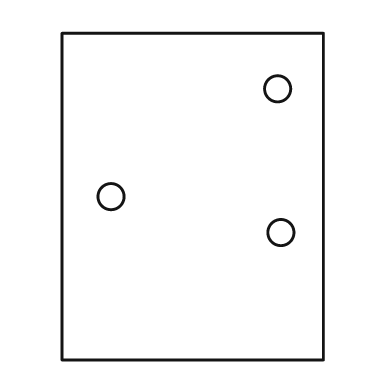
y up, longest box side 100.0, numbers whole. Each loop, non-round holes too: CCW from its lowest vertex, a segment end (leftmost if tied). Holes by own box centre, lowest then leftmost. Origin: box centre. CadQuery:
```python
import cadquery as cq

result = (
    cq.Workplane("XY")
    .moveTo(-40.0, -50.0)
    .lineTo(40.0, -50.0)
    .lineTo(40.0, 50.0)
    .lineTo(-40.0, 50.0)
    .close()
    .moveTo(27.0, -11.0)
    .circle(4.0)
    .moveTo(-25.0, 0.0)
    .circle(4.0)
    .moveTo(26.0, 33.0)
    .circle(4.0)
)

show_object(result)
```